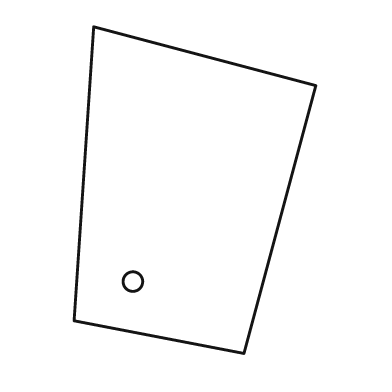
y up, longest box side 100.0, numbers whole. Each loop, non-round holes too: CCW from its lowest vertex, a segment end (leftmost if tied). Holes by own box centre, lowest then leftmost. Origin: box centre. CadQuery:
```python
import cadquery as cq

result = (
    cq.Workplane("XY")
    .moveTo(15.0, -50.0)
    .lineTo(37.0, 32.0)
    .lineTo(-31.0, 50.0)
    .lineTo(-37.0, -40.0)
    .close()
    .moveTo(-19.0, -28.0)
    .circle(3.0)
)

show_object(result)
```